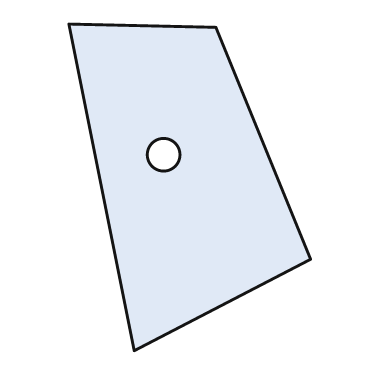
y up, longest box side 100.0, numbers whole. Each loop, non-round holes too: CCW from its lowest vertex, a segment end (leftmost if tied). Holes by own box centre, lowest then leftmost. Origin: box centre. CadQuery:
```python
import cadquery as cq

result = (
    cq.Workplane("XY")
    .moveTo(-17.0, -50.0)
    .lineTo(37.0, -22.0)
    .lineTo(8.0, 49.0)
    .lineTo(-37.0, 50.0)
    .close()
    .moveTo(-8.0, 10.0)
    .circle(5.0)
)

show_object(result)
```